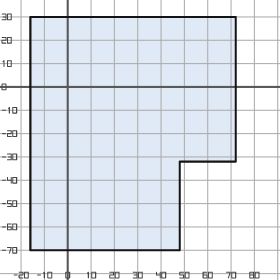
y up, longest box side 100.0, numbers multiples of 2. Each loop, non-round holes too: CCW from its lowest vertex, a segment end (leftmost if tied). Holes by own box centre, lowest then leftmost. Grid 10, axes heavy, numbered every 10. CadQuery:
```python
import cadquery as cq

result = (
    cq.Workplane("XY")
    .moveTo(-16.0, -70.0)
    .lineTo(48.0, -70.0)
    .lineTo(48.0, -32.0)
    .lineTo(72.0, -32.0)
    .lineTo(72.0, 30.0)
    .lineTo(-16.0, 30.0)
    .close()
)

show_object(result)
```